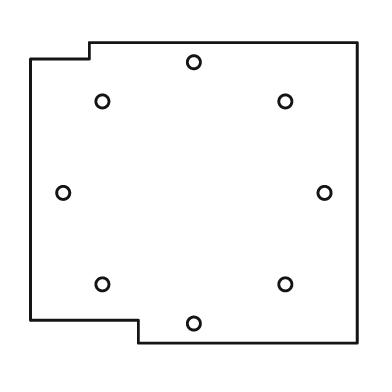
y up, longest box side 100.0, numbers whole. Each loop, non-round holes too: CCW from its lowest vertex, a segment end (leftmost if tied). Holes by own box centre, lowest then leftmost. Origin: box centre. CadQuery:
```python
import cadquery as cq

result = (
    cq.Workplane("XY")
    .moveTo(-17.0, -46.0)
    .lineTo(50.0, -46.0)
    .lineTo(50.0, 46.0)
    .lineTo(-32.0, 46.0)
    .lineTo(-32.0, 41.0)
    .lineTo(-50.0, 41.0)
    .lineTo(-50.0, -39.0)
    .lineTo(-17.0, -39.0)
    .close()
    .moveTo(0.0, -40.0)
    .circle(2.0)
    .moveTo(-28.0, -28.0)
    .circle(2.0)
    .moveTo(28.0, -28.0)
    .circle(2.0)
    .moveTo(-40.0, 0.0)
    .circle(2.0)
    .moveTo(40.0, 0.0)
    .circle(2.0)
    .moveTo(-28.0, 28.0)
    .circle(2.0)
    .moveTo(28.0, 28.0)
    .circle(2.0)
    .moveTo(0.0, 40.0)
    .circle(2.0)
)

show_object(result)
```